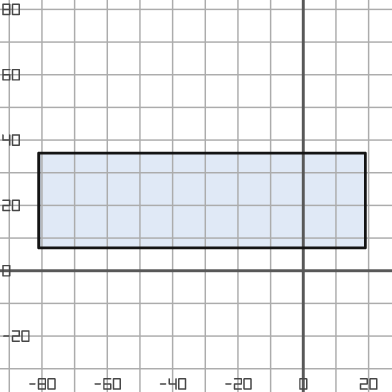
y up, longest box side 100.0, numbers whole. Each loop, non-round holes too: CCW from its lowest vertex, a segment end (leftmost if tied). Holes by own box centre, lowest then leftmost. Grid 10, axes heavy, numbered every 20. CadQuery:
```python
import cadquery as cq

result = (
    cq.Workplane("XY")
    .moveTo(-81.0, 7.0)
    .lineTo(19.0, 7.0)
    .lineTo(19.0, 36.0)
    .lineTo(-81.0, 36.0)
    .close()
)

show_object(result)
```